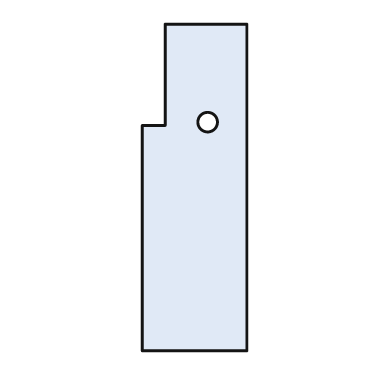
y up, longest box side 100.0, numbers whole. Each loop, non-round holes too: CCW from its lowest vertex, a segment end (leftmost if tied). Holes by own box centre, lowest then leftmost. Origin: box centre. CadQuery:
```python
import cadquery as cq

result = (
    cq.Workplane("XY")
    .moveTo(-16.0, -50.0)
    .lineTo(16.0, -50.0)
    .lineTo(16.0, 50.0)
    .lineTo(-9.0, 50.0)
    .lineTo(-9.0, 19.0)
    .lineTo(-16.0, 19.0)
    .close()
    .moveTo(4.0, 20.0)
    .circle(3.0)
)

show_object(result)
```